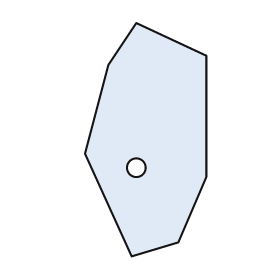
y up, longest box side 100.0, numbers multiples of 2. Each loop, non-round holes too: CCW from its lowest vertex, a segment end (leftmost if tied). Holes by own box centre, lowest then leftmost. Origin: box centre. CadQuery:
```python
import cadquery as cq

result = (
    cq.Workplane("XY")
    .moveTo(-6.0, -50.0)
    .lineTo(14.0, -44.0)
    .lineTo(26.0, -16.0)
    .lineTo(26.0, 36.0)
    .lineTo(-4.0, 50.0)
    .lineTo(-16.0, 32.0)
    .lineTo(-26.0, -6.0)
    .close()
    .moveTo(-4.0, -12.0)
    .circle(4.0)
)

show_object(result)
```